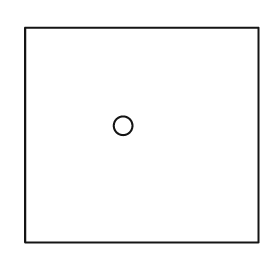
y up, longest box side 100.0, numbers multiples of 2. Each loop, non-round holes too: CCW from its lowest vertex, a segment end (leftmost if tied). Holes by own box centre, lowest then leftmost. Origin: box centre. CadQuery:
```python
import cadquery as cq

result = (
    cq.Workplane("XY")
    .moveTo(-50.0, -46.0)
    .lineTo(50.0, -46.0)
    .lineTo(50.0, 46.0)
    .lineTo(-50.0, 46.0)
    .close()
    .moveTo(-8.0, 4.0)
    .circle(4.0)
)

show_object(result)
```